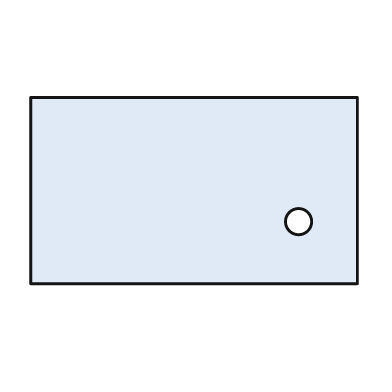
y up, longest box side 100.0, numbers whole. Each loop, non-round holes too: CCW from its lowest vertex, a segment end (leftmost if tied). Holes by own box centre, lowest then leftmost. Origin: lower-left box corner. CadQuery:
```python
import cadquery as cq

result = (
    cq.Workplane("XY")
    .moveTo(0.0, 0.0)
    .lineTo(100.0, 0.0)
    .lineTo(100.0, 57.0)
    .lineTo(0.0, 57.0)
    .close()
    .moveTo(82.0, 19.0)
    .circle(4.0)
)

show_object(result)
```